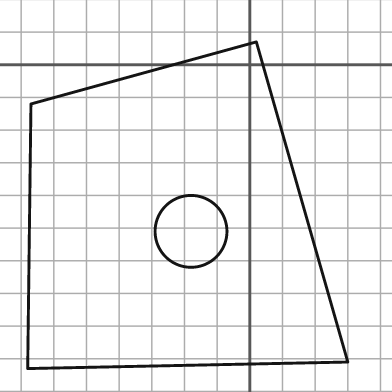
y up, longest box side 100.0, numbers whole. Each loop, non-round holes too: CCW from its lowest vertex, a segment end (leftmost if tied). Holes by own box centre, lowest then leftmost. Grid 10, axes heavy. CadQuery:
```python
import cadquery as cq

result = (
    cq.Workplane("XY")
    .moveTo(-68.0, -93.0)
    .lineTo(30.0, -91.0)
    .lineTo(2.0, 7.0)
    .lineTo(-67.0, -12.0)
    .close()
    .moveTo(-18.0, -51.0)
    .circle(11.0)
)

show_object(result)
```